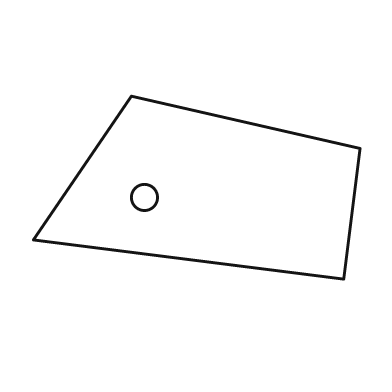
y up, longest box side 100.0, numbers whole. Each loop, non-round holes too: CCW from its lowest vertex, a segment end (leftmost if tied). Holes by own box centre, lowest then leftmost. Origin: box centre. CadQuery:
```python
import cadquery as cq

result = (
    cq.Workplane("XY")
    .moveTo(45.0, -28.0)
    .lineTo(50.0, 12.0)
    .lineTo(-20.0, 28.0)
    .lineTo(-50.0, -16.0)
    .close()
    .moveTo(-16.0, -3.0)
    .circle(4.0)
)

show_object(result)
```